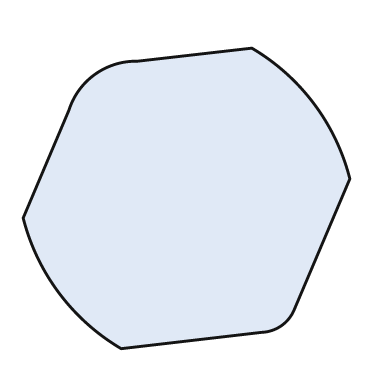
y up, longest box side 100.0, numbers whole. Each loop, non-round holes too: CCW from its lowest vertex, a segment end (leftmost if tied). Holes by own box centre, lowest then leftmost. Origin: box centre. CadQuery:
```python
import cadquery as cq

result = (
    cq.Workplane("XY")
    .moveTo(-20.0, -46.0)
    .lineTo(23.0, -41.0)
    .threePointArc((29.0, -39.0), (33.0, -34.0))
    .lineTo(50.0, 6.0)
    .threePointArc((39.0, 29.0), (20.0, 46.0))
    .lineTo(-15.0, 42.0)
    .threePointArc((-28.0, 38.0), (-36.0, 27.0))
    .lineTo(-50.0, -6.0)
    .threePointArc((-39.0, -29.0), (-20.0, -46.0))
    .close()
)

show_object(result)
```